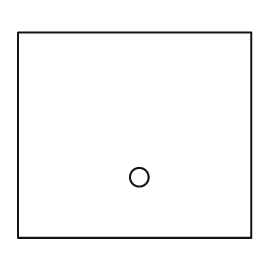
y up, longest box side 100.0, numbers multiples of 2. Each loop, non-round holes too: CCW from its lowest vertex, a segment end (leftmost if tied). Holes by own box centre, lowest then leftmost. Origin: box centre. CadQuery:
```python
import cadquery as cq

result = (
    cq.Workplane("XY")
    .moveTo(-50.0, -44.0)
    .lineTo(50.0, -44.0)
    .lineTo(50.0, 44.0)
    .lineTo(-50.0, 44.0)
    .close()
    .moveTo(2.0, -18.0)
    .circle(4.0)
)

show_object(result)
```